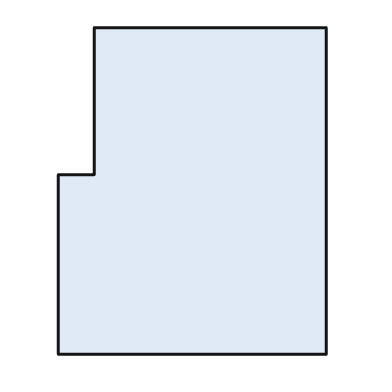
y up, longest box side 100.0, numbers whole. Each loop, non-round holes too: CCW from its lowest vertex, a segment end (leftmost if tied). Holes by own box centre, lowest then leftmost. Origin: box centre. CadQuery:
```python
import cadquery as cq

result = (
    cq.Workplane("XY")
    .moveTo(-41.0, -50.0)
    .lineTo(41.0, -50.0)
    .lineTo(41.0, 50.0)
    .lineTo(-30.0, 50.0)
    .lineTo(-30.0, 5.0)
    .lineTo(-41.0, 5.0)
    .close()
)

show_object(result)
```